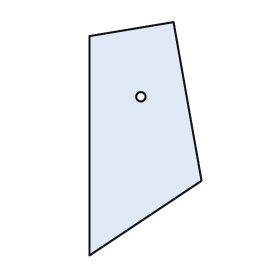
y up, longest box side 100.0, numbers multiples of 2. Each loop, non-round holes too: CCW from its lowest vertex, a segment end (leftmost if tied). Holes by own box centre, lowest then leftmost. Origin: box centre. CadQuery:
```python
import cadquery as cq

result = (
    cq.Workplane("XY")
    .moveTo(-24.0, -50.0)
    .lineTo(24.0, -18.0)
    .lineTo(12.0, 50.0)
    .lineTo(-24.0, 44.0)
    .close()
    .moveTo(-2.0, 18.0)
    .circle(2.0)
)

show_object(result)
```